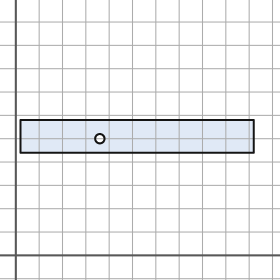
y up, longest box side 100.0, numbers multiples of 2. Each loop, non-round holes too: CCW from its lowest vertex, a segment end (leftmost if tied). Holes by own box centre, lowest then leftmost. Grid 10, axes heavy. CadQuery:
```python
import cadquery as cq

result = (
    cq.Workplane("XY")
    .moveTo(2.0, 44.0)
    .lineTo(102.0, 44.0)
    .lineTo(102.0, 58.0)
    .lineTo(2.0, 58.0)
    .close()
    .moveTo(36.0, 50.0)
    .circle(2.0)
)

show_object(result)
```